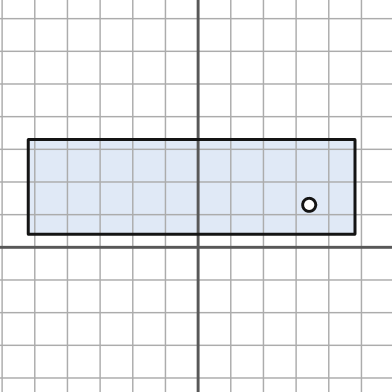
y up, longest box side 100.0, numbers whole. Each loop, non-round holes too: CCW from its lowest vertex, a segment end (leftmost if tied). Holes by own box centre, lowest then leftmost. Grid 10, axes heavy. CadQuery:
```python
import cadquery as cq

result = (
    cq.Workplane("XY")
    .moveTo(-52.0, 4.0)
    .lineTo(48.0, 4.0)
    .lineTo(48.0, 33.0)
    .lineTo(-52.0, 33.0)
    .close()
    .moveTo(34.0, 13.0)
    .circle(2.0)
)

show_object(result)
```